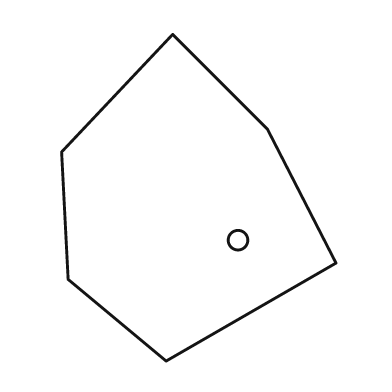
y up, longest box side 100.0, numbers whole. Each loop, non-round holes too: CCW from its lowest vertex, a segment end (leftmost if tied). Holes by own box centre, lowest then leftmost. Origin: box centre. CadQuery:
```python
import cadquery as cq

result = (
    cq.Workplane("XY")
    .moveTo(-10.0, -50.0)
    .lineTo(42.0, -20.0)
    .lineTo(21.0, 21.0)
    .lineTo(-8.0, 50.0)
    .lineTo(-42.0, 14.0)
    .lineTo(-40.0, -25.0)
    .close()
    .moveTo(12.0, -13.0)
    .circle(3.0)
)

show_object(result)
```